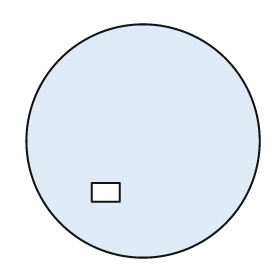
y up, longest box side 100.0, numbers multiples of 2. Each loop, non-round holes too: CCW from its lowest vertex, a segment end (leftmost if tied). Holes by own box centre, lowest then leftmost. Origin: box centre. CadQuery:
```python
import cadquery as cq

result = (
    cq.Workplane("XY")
    .moveTo(0.0, 0.0)
    .circle(50.0)
    .moveTo(-22.0, -26.0)
    .lineTo(-10.0, -26.0)
    .lineTo(-10.0, -18.0)
    .lineTo(-22.0, -18.0)
    .close()
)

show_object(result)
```